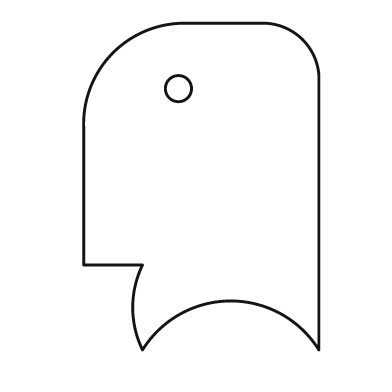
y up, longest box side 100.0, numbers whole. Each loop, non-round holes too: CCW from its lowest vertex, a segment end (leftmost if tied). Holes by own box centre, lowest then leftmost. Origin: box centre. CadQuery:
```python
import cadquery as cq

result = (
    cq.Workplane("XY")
    .moveTo(-18.0, -50.0)
    .threePointArc((9.0, -35.0), (36.0, -50.0))
    .lineTo(36.0, 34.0)
    .threePointArc((31.0, 45.0), (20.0, 50.0))
    .lineTo(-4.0, 50.0)
    .threePointArc((-27.0, 41.0), (-36.0, 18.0))
    .lineTo(-36.0, -24.0)
    .lineTo(-18.0, -24.0)
    .threePointArc((-21.0, -37.0), (-18.0, -50.0))
    .close()
    .moveTo(-7.0, 30.0)
    .circle(4.0)
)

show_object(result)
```